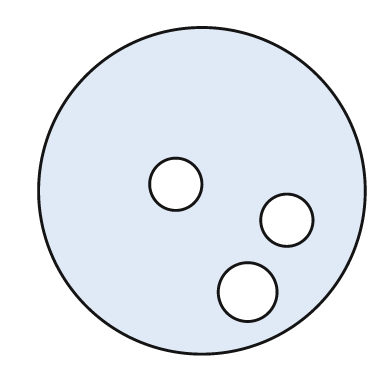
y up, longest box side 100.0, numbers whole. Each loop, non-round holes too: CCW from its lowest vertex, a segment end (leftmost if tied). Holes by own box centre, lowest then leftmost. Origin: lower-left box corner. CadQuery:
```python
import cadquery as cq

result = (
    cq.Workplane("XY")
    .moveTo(50.0, 50.0)
    .circle(50.0)
    .moveTo(64.0, 19.0)
    .circle(9.0)
    .moveTo(76.0, 41.0)
    .circle(8.0)
    .moveTo(42.0, 52.0)
    .circle(8.0)
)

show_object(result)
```